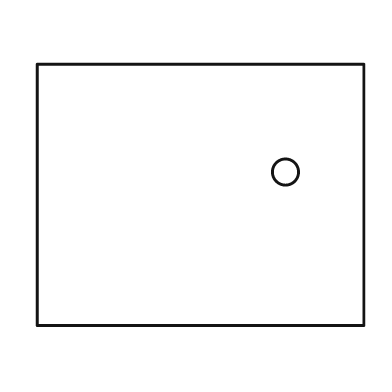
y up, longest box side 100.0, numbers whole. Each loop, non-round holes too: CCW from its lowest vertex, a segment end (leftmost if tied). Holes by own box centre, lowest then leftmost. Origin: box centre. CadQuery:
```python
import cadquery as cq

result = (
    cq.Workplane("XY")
    .moveTo(-50.0, -40.0)
    .lineTo(50.0, -40.0)
    .lineTo(50.0, 40.0)
    .lineTo(-50.0, 40.0)
    .close()
    .moveTo(26.0, 7.0)
    .circle(4.0)
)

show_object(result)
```